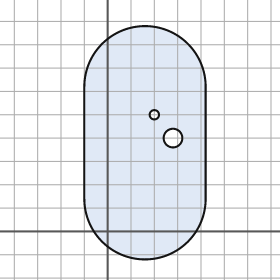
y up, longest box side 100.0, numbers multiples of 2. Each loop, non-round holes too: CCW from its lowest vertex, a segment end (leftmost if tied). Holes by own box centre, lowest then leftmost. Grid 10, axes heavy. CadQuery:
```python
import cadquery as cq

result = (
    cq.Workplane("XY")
    .moveTo(-10.0, 14.0)
    .threePointArc((16.0, -12.0), (42.0, 14.0))
    .lineTo(42.0, 62.0)
    .threePointArc((16.0, 88.0), (-10.0, 62.0))
    .close()
    .moveTo(28.0, 40.0)
    .circle(4.0)
    .moveTo(20.0, 50.0)
    .circle(2.0)
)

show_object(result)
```